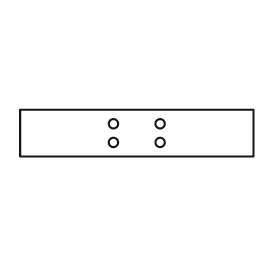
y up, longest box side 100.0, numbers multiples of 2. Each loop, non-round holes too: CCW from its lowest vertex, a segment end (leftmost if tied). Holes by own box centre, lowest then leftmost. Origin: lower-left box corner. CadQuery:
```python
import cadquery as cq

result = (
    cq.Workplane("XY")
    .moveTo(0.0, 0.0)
    .lineTo(100.0, 0.0)
    .lineTo(100.0, 20.0)
    .lineTo(0.0, 20.0)
    .close()
    .moveTo(40.0, 6.0)
    .circle(2.0)
    .moveTo(60.0, 6.0)
    .circle(2.0)
    .moveTo(40.0, 14.0)
    .circle(2.0)
    .moveTo(60.0, 14.0)
    .circle(2.0)
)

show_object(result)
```